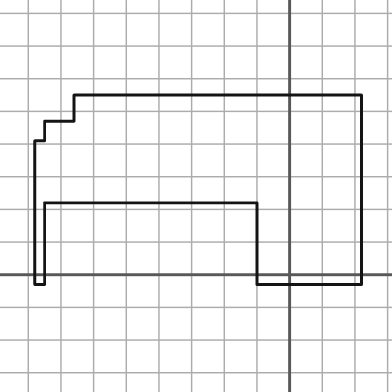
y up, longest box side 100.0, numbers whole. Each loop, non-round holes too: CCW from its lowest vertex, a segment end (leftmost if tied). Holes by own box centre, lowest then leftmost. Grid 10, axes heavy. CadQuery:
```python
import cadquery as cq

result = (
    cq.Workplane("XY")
    .moveTo(-78.0, -3.0)
    .lineTo(-75.0, -3.0)
    .lineTo(-75.0, 22.0)
    .lineTo(-10.0, 22.0)
    .lineTo(-10.0, -3.0)
    .lineTo(22.0, -3.0)
    .lineTo(22.0, 55.0)
    .lineTo(-66.0, 55.0)
    .lineTo(-66.0, 47.0)
    .lineTo(-75.0, 47.0)
    .lineTo(-75.0, 41.0)
    .lineTo(-78.0, 41.0)
    .close()
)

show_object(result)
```